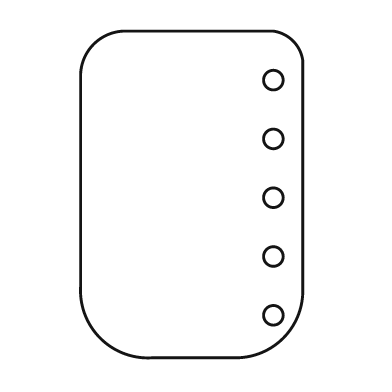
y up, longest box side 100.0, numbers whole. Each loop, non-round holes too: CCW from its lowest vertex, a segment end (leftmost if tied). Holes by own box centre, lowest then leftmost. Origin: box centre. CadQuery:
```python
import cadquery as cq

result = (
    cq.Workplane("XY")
    .moveTo(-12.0, -50.0)
    .lineTo(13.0, -50.0)
    .threePointArc((28.0, -44.0), (34.0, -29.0))
    .lineTo(34.0, 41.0)
    .threePointArc((31.0, 47.0), (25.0, 50.0))
    .lineTo(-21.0, 50.0)
    .threePointArc((-30.0, 46.0), (-34.0, 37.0))
    .lineTo(-34.0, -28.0)
    .threePointArc((-28.0, -44.0), (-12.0, -50.0))
    .close()
    .moveTo(25.0, -37.0)
    .circle(3.0)
    .moveTo(25.0, -19.0)
    .circle(3.0)
    .moveTo(25.0, -1.0)
    .circle(3.0)
    .moveTo(25.0, 17.0)
    .circle(3.0)
    .moveTo(25.0, 35.0)
    .circle(3.0)
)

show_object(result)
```